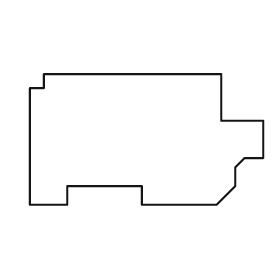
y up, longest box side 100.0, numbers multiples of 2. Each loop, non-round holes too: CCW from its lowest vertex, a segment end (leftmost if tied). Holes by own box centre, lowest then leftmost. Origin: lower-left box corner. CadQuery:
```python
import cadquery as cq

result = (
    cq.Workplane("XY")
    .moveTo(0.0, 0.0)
    .lineTo(16.0, 0.0)
    .lineTo(16.0, 8.0)
    .lineTo(48.0, 8.0)
    .lineTo(48.0, 0.0)
    .lineTo(80.0, 0.0)
    .lineTo(88.0, 8.0)
    .lineTo(88.0, 16.0)
    .lineTo(92.0, 20.0)
    .lineTo(100.0, 20.0)
    .lineTo(100.0, 36.0)
    .lineTo(82.0, 36.0)
    .lineTo(82.0, 56.0)
    .lineTo(6.0, 56.0)
    .lineTo(6.0, 50.0)
    .lineTo(0.0, 50.0)
    .close()
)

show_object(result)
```